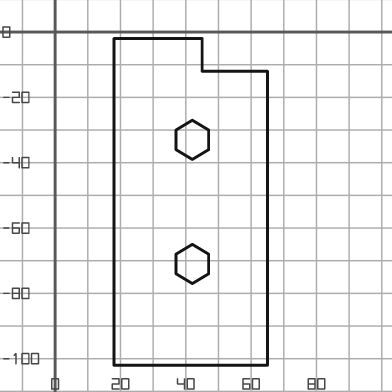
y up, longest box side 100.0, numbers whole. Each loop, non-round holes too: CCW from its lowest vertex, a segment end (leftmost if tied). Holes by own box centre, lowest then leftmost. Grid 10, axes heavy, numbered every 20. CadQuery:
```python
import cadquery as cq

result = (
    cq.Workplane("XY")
    .moveTo(18.0, -102.0)
    .lineTo(65.0, -102.0)
    .lineTo(65.0, -12.0)
    .lineTo(45.0, -12.0)
    .lineTo(45.0, -2.0)
    .lineTo(18.0, -2.0)
    .close()
    .moveTo(42.0, -77.0)
    .lineTo(47.0, -74.0)
    .lineTo(47.0, -68.0)
    .lineTo(42.0, -65.0)
    .lineTo(37.0, -68.0)
    .lineTo(37.0, -74.0)
    .close()
    .moveTo(42.0, -39.0)
    .lineTo(47.0, -36.0)
    .lineTo(47.0, -30.0)
    .lineTo(42.0, -27.0)
    .lineTo(37.0, -30.0)
    .lineTo(37.0, -36.0)
    .close()
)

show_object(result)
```